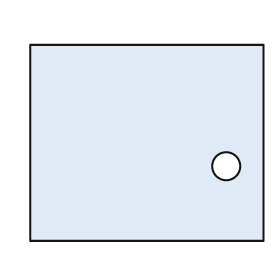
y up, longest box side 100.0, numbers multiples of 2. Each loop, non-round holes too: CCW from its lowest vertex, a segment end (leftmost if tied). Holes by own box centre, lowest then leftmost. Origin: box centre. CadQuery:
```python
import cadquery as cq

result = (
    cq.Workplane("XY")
    .moveTo(-50.0, -42.0)
    .lineTo(50.0, -42.0)
    .lineTo(50.0, 42.0)
    .lineTo(-50.0, 42.0)
    .close()
    .moveTo(34.0, -10.0)
    .circle(6.0)
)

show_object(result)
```